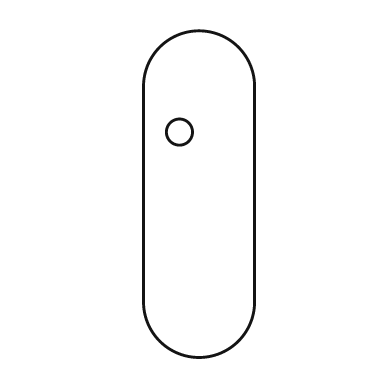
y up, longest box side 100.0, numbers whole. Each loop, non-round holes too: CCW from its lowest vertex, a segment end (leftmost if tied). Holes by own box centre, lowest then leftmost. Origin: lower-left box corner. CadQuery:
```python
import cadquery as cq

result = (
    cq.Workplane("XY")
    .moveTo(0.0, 17.0)
    .threePointArc((17.0, 0.0), (34.0, 17.0))
    .lineTo(34.0, 83.0)
    .threePointArc((17.0, 100.0), (0.0, 83.0))
    .close()
    .moveTo(11.0, 69.0)
    .circle(4.0)
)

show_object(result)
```